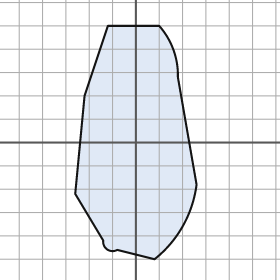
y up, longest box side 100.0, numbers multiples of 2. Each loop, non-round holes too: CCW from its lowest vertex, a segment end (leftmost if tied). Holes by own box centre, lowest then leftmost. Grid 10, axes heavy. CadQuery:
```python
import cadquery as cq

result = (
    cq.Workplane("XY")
    .moveTo(8.0, -50.0)
    .threePointArc((20.0, -36.0), (26.0, -18.0))
    .lineTo(18.0, 28.0)
    .threePointArc((16.0, 40.0), (10.0, 50.0))
    .lineTo(-12.0, 50.0)
    .lineTo(-22.0, 20.0)
    .lineTo(-26.0, -22.0)
    .lineTo(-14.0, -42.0)
    .threePointArc((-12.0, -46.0), (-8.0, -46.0))
    .close()
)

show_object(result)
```